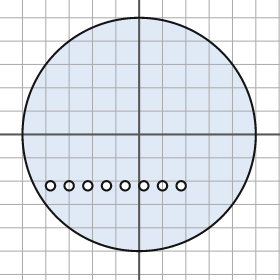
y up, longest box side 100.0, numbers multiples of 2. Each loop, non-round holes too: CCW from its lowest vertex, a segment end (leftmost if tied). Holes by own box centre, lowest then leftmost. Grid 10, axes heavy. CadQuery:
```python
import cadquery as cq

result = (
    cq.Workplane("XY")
    .moveTo(0.0, 0.0)
    .circle(50.0)
    .moveTo(-38.0, -22.0)
    .circle(2.0)
    .moveTo(-30.0, -22.0)
    .circle(2.0)
    .moveTo(-22.0, -22.0)
    .circle(2.0)
    .moveTo(-14.0, -22.0)
    .circle(2.0)
    .moveTo(-6.0, -22.0)
    .circle(2.0)
    .moveTo(2.0, -22.0)
    .circle(2.0)
    .moveTo(10.0, -22.0)
    .circle(2.0)
    .moveTo(18.0, -22.0)
    .circle(2.0)
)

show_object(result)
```